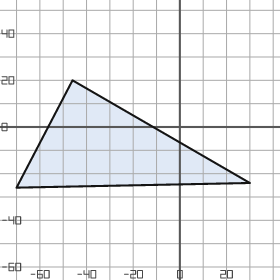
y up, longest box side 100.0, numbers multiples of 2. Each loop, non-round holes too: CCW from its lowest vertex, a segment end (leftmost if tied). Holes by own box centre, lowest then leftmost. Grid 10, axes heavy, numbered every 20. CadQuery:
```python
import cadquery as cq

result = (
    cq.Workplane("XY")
    .moveTo(-70.0, -26.0)
    .lineTo(30.0, -24.0)
    .lineTo(-46.0, 20.0)
    .close()
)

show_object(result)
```